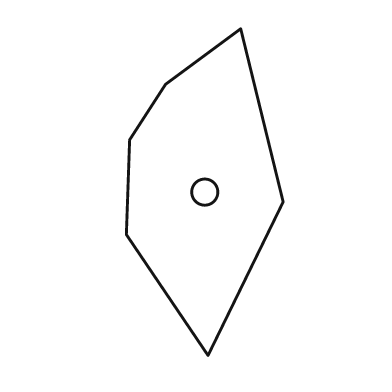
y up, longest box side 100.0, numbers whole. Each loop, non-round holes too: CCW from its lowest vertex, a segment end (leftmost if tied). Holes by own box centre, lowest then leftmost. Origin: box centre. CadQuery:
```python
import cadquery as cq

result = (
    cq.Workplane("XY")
    .moveTo(1.0, -50.0)
    .lineTo(24.0, -3.0)
    .lineTo(11.0, 50.0)
    .lineTo(-12.0, 33.0)
    .lineTo(-23.0, 16.0)
    .lineTo(-24.0, -13.0)
    .close()
    .moveTo(0.0, 0.0)
    .circle(4.0)
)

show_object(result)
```